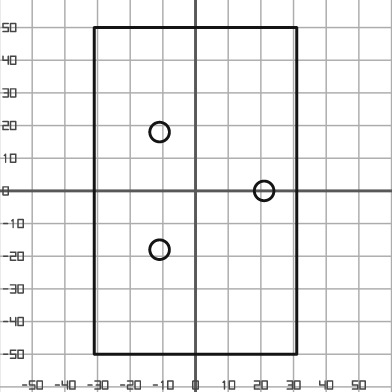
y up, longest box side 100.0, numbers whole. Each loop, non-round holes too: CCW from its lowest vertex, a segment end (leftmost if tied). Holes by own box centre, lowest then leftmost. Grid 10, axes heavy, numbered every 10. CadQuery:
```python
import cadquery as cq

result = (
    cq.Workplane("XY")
    .moveTo(-31.0, -50.0)
    .lineTo(31.0, -50.0)
    .lineTo(31.0, 50.0)
    .lineTo(-31.0, 50.0)
    .close()
    .moveTo(-11.0, -18.0)
    .circle(3.0)
    .moveTo(21.0, 0.0)
    .circle(3.0)
    .moveTo(-11.0, 18.0)
    .circle(3.0)
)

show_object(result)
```